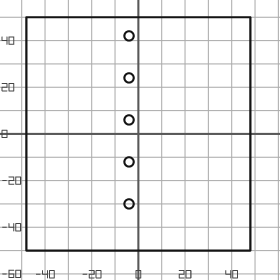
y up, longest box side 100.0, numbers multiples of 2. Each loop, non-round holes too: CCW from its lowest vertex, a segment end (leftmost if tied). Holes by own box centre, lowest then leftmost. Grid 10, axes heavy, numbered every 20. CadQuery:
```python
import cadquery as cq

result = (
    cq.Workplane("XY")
    .moveTo(-48.0, -50.0)
    .lineTo(48.0, -50.0)
    .lineTo(48.0, 50.0)
    .lineTo(-48.0, 50.0)
    .close()
    .moveTo(-4.0, -30.0)
    .circle(2.0)
    .moveTo(-4.0, -12.0)
    .circle(2.0)
    .moveTo(-4.0, 6.0)
    .circle(2.0)
    .moveTo(-4.0, 24.0)
    .circle(2.0)
    .moveTo(-4.0, 42.0)
    .circle(2.0)
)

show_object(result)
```